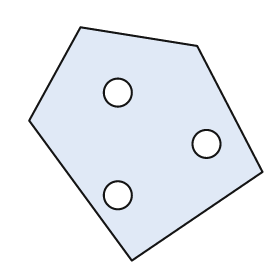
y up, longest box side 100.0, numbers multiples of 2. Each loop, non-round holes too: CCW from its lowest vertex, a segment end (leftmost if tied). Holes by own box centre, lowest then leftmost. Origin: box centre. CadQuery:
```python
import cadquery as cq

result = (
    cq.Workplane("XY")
    .moveTo(-6.0, -50.0)
    .lineTo(50.0, -12.0)
    .lineTo(22.0, 42.0)
    .lineTo(-28.0, 50.0)
    .lineTo(-50.0, 10.0)
    .close()
    .moveTo(-12.0, -22.0)
    .circle(6.0)
    .moveTo(26.0, 0.0)
    .circle(6.0)
    .moveTo(-12.0, 22.0)
    .circle(6.0)
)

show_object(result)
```